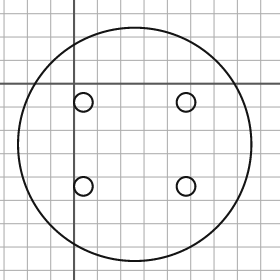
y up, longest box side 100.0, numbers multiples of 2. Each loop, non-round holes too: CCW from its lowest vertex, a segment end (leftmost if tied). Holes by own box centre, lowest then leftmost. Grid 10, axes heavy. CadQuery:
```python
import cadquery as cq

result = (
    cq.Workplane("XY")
    .moveTo(26.0, -26.0)
    .circle(50.0)
    .moveTo(4.0, -44.0)
    .circle(4.0)
    .moveTo(48.0, -44.0)
    .circle(4.0)
    .moveTo(4.0, -8.0)
    .circle(4.0)
    .moveTo(48.0, -8.0)
    .circle(4.0)
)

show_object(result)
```